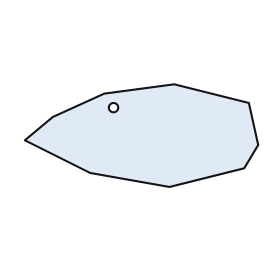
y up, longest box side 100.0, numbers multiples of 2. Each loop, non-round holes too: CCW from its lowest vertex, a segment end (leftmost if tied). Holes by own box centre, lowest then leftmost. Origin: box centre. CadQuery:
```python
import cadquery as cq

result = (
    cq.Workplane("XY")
    .moveTo(12.0, -22.0)
    .lineTo(44.0, -14.0)
    .lineTo(50.0, -4.0)
    .lineTo(46.0, 14.0)
    .lineTo(14.0, 22.0)
    .lineTo(-16.0, 18.0)
    .lineTo(-38.0, 8.0)
    .lineTo(-50.0, -2.0)
    .lineTo(-22.0, -16.0)
    .close()
    .moveTo(-12.0, 12.0)
    .circle(2.0)
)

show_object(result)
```